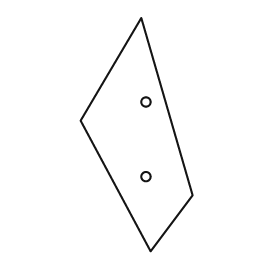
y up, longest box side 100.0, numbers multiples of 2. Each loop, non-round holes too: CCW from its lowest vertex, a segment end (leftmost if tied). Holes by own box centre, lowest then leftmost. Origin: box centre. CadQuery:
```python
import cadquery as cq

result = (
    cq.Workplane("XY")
    .moveTo(6.0, -50.0)
    .lineTo(24.0, -26.0)
    .lineTo(2.0, 50.0)
    .lineTo(-24.0, 6.0)
    .close()
    .moveTo(4.0, -18.0)
    .circle(2.0)
    .moveTo(4.0, 14.0)
    .circle(2.0)
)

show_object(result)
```